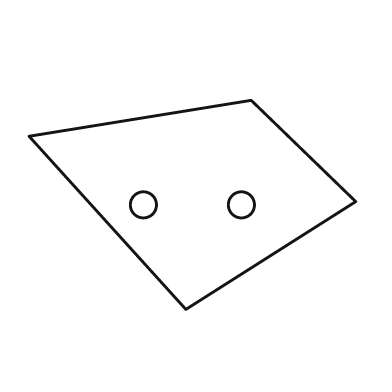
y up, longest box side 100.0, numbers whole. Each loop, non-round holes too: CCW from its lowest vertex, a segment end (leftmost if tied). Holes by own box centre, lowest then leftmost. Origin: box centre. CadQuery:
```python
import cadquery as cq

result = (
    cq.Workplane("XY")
    .moveTo(-2.0, -32.0)
    .lineTo(50.0, 1.0)
    .lineTo(18.0, 32.0)
    .lineTo(-50.0, 21.0)
    .close()
    .moveTo(-15.0, 0.0)
    .circle(4.0)
    .moveTo(15.0, 0.0)
    .circle(4.0)
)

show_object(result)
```